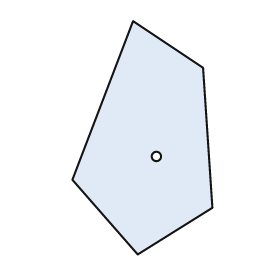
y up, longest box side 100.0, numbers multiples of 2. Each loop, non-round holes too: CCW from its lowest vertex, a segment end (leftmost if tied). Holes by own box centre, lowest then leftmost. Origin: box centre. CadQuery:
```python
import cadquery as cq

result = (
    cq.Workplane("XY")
    .moveTo(-2.0, -50.0)
    .lineTo(30.0, -30.0)
    .lineTo(26.0, 30.0)
    .lineTo(-4.0, 50.0)
    .lineTo(-30.0, -18.0)
    .close()
    .moveTo(6.0, -8.0)
    .circle(2.0)
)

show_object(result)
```